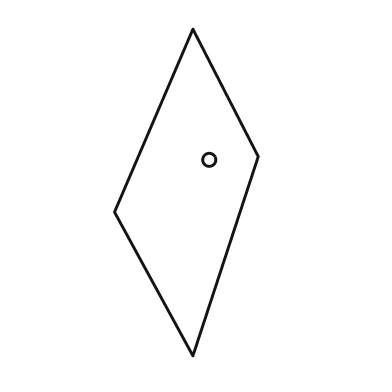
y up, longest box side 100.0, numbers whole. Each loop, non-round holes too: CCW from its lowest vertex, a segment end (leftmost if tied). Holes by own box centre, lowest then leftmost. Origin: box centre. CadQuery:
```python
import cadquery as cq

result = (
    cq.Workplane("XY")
    .moveTo(2.0, -50.0)
    .lineTo(22.0, 11.0)
    .lineTo(2.0, 50.0)
    .lineTo(-22.0, -6.0)
    .close()
    .moveTo(7.0, 10.0)
    .circle(2.0)
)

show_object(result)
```